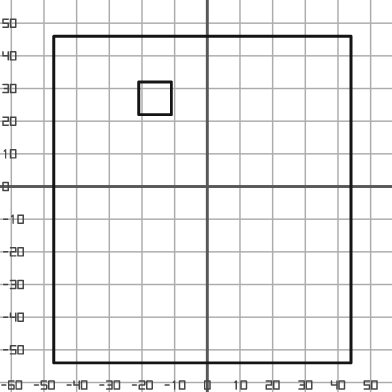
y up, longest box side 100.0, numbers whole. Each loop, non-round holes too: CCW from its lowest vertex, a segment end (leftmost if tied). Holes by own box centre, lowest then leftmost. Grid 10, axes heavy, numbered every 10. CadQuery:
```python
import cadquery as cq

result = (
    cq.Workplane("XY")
    .moveTo(-47.0, -54.0)
    .lineTo(44.0, -54.0)
    .lineTo(44.0, 46.0)
    .lineTo(-47.0, 46.0)
    .close()
    .moveTo(-21.0, 22.0)
    .lineTo(-11.0, 22.0)
    .lineTo(-11.0, 32.0)
    .lineTo(-21.0, 32.0)
    .close()
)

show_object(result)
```